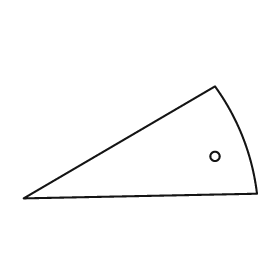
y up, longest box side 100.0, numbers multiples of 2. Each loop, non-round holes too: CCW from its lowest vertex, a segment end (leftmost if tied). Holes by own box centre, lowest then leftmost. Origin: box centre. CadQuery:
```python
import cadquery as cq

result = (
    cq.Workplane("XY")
    .moveTo(-50.0, -24.0)
    .lineTo(50.0, -22.0)
    .threePointArc((44.0, 2.0), (32.0, 24.0))
    .close()
    .moveTo(32.0, -6.0)
    .circle(2.0)
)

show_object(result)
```